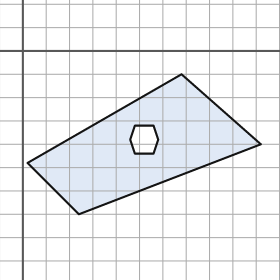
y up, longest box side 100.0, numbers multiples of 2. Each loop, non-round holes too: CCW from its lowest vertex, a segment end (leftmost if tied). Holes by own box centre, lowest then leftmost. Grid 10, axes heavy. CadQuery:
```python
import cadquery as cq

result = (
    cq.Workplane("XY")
    .moveTo(24.0, -70.0)
    .lineTo(102.0, -40.0)
    .lineTo(68.0, -10.0)
    .lineTo(2.0, -48.0)
    .close()
    .moveTo(48.0, -44.0)
    .lineTo(56.0, -44.0)
    .lineTo(58.0, -38.0)
    .lineTo(56.0, -32.0)
    .lineTo(48.0, -32.0)
    .lineTo(46.0, -38.0)
    .close()
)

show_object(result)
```